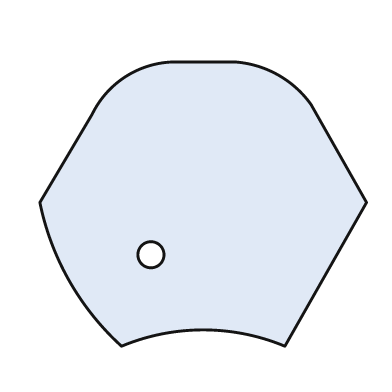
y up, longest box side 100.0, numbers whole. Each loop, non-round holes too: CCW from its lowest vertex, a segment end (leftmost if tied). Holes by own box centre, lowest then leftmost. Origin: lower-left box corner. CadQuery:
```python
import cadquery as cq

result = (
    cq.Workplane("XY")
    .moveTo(25.0, 0.0)
    .threePointArc((50.0, 5.0), (75.0, 0.0))
    .lineTo(100.0, 44.0)
    .lineTo(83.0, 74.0)
    .threePointArc((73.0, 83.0), (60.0, 87.0))
    .lineTo(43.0, 87.0)
    .threePointArc((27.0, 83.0), (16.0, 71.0))
    .lineTo(0.0, 44.0)
    .threePointArc((9.0, 20.0), (25.0, 0.0))
    .close()
    .moveTo(34.0, 28.0)
    .circle(4.0)
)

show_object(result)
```